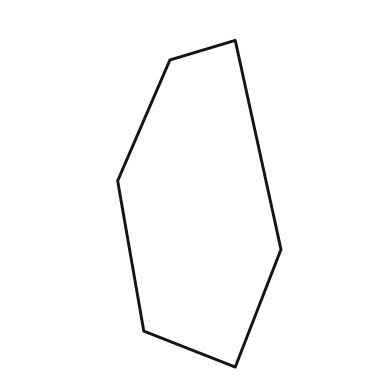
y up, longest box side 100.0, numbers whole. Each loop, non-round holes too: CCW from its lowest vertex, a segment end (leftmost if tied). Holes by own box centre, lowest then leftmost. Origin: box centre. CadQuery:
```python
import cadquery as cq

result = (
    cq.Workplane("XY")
    .moveTo(11.0, -50.0)
    .lineTo(25.0, -14.0)
    .lineTo(11.0, 50.0)
    .lineTo(-9.0, 44.0)
    .lineTo(-25.0, 7.0)
    .lineTo(-17.0, -39.0)
    .close()
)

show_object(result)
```